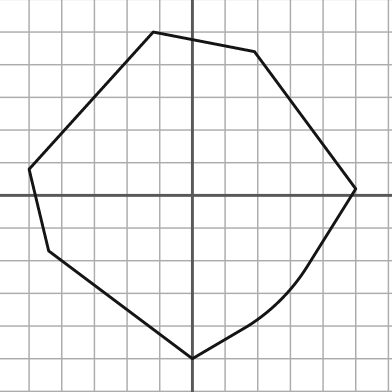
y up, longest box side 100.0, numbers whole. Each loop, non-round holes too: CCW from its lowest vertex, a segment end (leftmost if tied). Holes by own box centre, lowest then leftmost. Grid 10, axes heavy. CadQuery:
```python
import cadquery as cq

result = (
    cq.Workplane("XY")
    .moveTo(0.0, -50.0)
    .lineTo(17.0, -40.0)
    .threePointArc((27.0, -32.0), (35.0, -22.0))
    .lineTo(50.0, 2.0)
    .lineTo(19.0, 44.0)
    .lineTo(-12.0, 50.0)
    .lineTo(-50.0, 8.0)
    .lineTo(-44.0, -17.0)
    .close()
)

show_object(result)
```